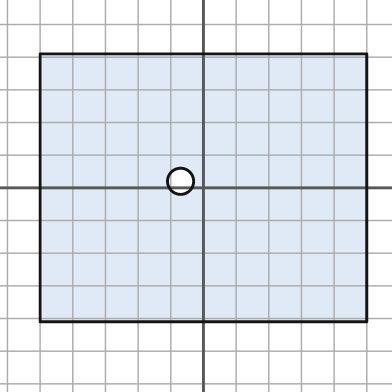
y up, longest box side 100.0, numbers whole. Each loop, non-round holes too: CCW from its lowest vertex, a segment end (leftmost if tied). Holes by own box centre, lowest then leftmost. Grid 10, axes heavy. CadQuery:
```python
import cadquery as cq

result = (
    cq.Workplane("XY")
    .moveTo(-50.0, -41.0)
    .lineTo(50.0, -41.0)
    .lineTo(50.0, 41.0)
    .lineTo(-50.0, 41.0)
    .close()
    .moveTo(-7.0, 2.0)
    .circle(4.0)
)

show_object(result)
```